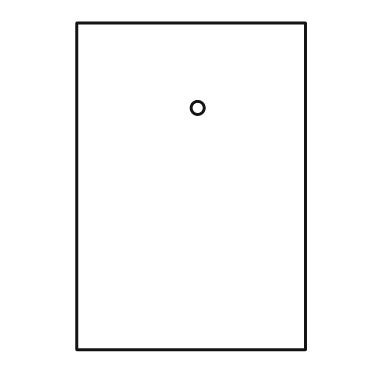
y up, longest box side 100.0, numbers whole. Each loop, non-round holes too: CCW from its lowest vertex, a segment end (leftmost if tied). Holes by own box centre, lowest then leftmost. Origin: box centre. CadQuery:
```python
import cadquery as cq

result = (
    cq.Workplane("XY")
    .moveTo(-35.0, -50.0)
    .lineTo(35.0, -50.0)
    .lineTo(35.0, 50.0)
    .lineTo(-35.0, 50.0)
    .close()
    .moveTo(2.0, 24.0)
    .circle(2.0)
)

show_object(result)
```